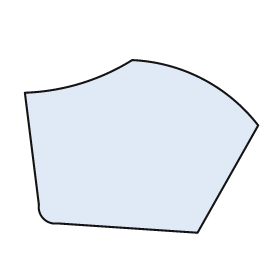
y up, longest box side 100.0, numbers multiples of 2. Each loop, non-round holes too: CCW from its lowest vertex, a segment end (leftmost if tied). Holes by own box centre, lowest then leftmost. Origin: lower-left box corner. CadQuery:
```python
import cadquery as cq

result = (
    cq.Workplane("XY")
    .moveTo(74.0, 0.0)
    .lineTo(100.0, 46.0)
    .threePointArc((76.0, 66.0), (46.0, 74.0))
    .threePointArc((24.0, 64.0), (0.0, 60.0))
    .lineTo(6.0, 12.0)
    .threePointArc((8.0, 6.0), (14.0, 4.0))
    .close()
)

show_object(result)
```